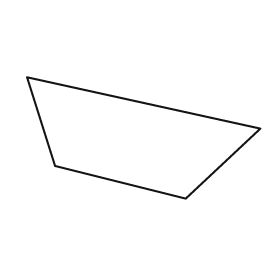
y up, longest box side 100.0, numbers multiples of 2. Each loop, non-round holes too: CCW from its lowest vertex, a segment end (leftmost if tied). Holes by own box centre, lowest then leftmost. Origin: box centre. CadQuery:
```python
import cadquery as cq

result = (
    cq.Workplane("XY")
    .moveTo(18.0, -26.0)
    .lineTo(50.0, 4.0)
    .lineTo(-50.0, 26.0)
    .lineTo(-38.0, -12.0)
    .close()
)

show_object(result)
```